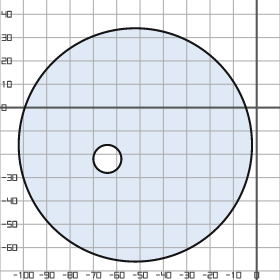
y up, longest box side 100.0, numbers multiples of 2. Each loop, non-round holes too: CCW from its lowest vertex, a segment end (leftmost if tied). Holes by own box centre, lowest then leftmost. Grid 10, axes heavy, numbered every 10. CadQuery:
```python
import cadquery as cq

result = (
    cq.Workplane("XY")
    .moveTo(-52.0, -16.0)
    .circle(50.0)
    .moveTo(-64.0, -22.0)
    .circle(6.0)
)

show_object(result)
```